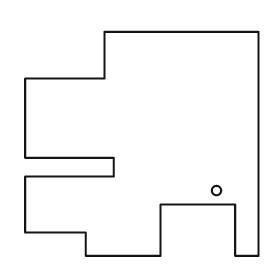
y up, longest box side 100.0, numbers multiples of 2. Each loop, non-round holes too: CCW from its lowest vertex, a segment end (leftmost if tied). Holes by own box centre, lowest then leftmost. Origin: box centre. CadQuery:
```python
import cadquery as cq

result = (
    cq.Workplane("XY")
    .moveTo(-24.0, -48.0)
    .lineTo(8.0, -48.0)
    .lineTo(8.0, -26.0)
    .lineTo(40.0, -26.0)
    .lineTo(40.0, -48.0)
    .lineTo(50.0, -48.0)
    .lineTo(50.0, 48.0)
    .lineTo(-16.0, 48.0)
    .lineTo(-16.0, 28.0)
    .lineTo(-50.0, 28.0)
    .lineTo(-50.0, -6.0)
    .lineTo(-12.0, -6.0)
    .lineTo(-12.0, -14.0)
    .lineTo(-50.0, -14.0)
    .lineTo(-50.0, -38.0)
    .lineTo(-24.0, -38.0)
    .close()
    .moveTo(32.0, -20.0)
    .circle(2.0)
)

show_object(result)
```